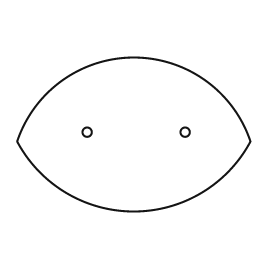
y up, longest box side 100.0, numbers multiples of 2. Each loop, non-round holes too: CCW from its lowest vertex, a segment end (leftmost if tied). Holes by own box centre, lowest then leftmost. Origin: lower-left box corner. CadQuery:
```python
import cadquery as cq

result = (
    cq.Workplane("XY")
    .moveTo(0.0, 30.0)
    .threePointArc((50.0, 0.0), (100.0, 30.0))
    .threePointArc((50.0, 66.0), (0.0, 30.0))
    .close()
    .moveTo(30.0, 34.0)
    .circle(2.0)
    .moveTo(72.0, 34.0)
    .circle(2.0)
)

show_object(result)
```